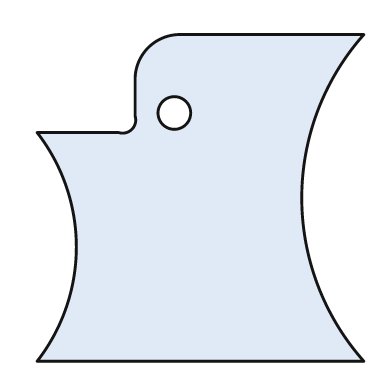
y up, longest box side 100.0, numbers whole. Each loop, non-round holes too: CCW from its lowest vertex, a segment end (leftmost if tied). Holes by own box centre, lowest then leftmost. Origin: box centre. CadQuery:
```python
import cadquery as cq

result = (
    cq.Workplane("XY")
    .moveTo(-50.0, -50.0)
    .lineTo(50.0, -50.0)
    .threePointArc((31.0, 0.0), (50.0, 50.0))
    .lineTo(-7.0, 50.0)
    .threePointArc((-16.0, 46.0), (-20.0, 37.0))
    .lineTo(-20.0, 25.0)
    .threePointArc((-21.0, 21.0), (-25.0, 20.0))
    .lineTo(-50.0, 20.0)
    .threePointArc((-38.0, -15.0), (-50.0, -50.0))
    .close()
    .moveTo(-8.0, 26.0)
    .circle(5.0)
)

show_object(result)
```